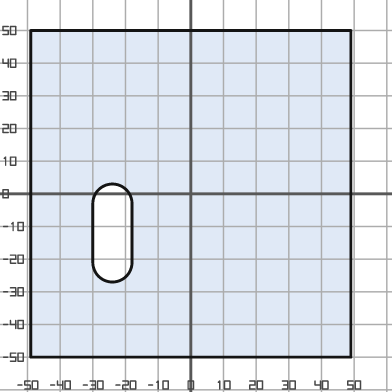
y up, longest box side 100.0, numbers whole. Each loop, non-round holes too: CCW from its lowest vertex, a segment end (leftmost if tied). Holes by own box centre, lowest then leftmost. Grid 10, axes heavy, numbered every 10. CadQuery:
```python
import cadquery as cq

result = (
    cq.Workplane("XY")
    .moveTo(-49.0, -50.0)
    .lineTo(49.0, -50.0)
    .lineTo(49.0, 50.0)
    .lineTo(-49.0, 50.0)
    .close()
    .moveTo(-30.0, -21.0)
    .threePointArc((-24.0, -27.0), (-18.0, -21.0))
    .lineTo(-18.0, -3.0)
    .threePointArc((-24.0, 3.0), (-30.0, -3.0))
    .close()
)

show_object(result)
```